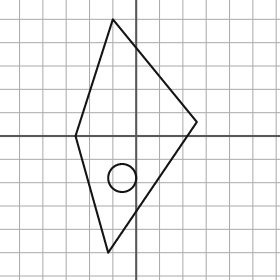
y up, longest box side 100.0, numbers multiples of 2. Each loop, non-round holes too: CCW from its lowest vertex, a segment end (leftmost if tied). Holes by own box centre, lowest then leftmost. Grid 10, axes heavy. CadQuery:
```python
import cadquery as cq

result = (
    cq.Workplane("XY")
    .moveTo(-12.0, -50.0)
    .lineTo(26.0, 6.0)
    .lineTo(-10.0, 50.0)
    .lineTo(-26.0, 0.0)
    .close()
    .moveTo(-6.0, -18.0)
    .circle(6.0)
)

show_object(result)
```